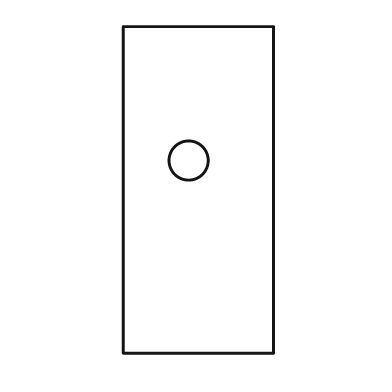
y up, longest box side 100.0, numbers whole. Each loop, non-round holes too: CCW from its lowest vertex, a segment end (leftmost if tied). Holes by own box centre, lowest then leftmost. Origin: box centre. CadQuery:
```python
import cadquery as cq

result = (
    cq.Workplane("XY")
    .moveTo(-23.0, -50.0)
    .lineTo(23.0, -50.0)
    .lineTo(23.0, 50.0)
    .lineTo(-23.0, 50.0)
    .close()
    .moveTo(-3.0, 9.0)
    .circle(6.0)
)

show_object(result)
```